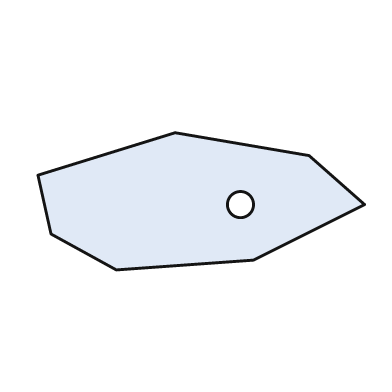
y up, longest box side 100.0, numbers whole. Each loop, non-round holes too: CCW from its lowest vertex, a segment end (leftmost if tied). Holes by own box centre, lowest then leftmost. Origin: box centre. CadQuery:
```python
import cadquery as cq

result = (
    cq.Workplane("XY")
    .moveTo(-26.0, -21.0)
    .lineTo(16.0, -18.0)
    .lineTo(50.0, -1.0)
    .lineTo(33.0, 14.0)
    .lineTo(-8.0, 21.0)
    .lineTo(-50.0, 8.0)
    .lineTo(-46.0, -10.0)
    .close()
    .moveTo(12.0, -1.0)
    .circle(4.0)
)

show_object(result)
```